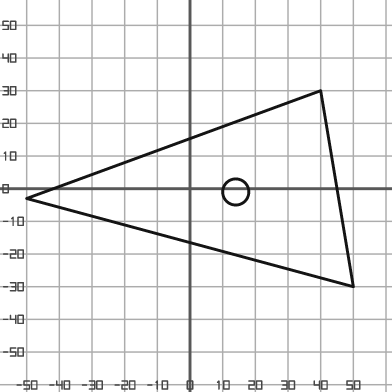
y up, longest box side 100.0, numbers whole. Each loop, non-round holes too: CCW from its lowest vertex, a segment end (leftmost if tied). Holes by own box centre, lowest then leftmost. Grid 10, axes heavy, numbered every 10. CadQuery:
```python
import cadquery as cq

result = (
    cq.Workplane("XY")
    .moveTo(50.0, -30.0)
    .lineTo(40.0, 30.0)
    .lineTo(-50.0, -3.0)
    .close()
    .moveTo(14.0, -1.0)
    .circle(4.0)
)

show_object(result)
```